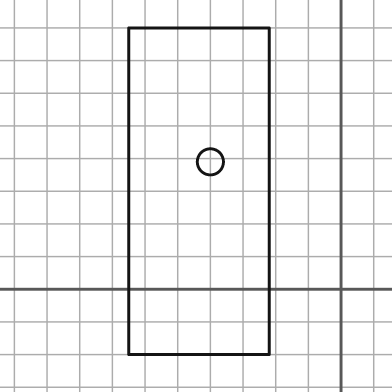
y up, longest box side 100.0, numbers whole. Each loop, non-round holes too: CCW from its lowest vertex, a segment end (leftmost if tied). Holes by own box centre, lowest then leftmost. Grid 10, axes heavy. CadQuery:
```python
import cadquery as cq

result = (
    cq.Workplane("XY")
    .moveTo(-65.0, -20.0)
    .lineTo(-22.0, -20.0)
    .lineTo(-22.0, 80.0)
    .lineTo(-65.0, 80.0)
    .close()
    .moveTo(-40.0, 39.0)
    .circle(4.0)
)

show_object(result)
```